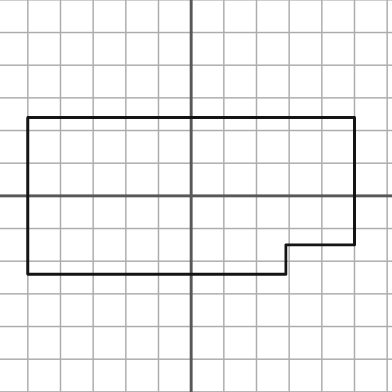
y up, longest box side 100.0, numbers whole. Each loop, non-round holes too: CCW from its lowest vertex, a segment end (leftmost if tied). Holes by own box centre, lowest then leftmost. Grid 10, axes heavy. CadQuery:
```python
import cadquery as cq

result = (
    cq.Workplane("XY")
    .moveTo(-50.0, -24.0)
    .lineTo(29.0, -24.0)
    .lineTo(29.0, -15.0)
    .lineTo(50.0, -15.0)
    .lineTo(50.0, 24.0)
    .lineTo(-50.0, 24.0)
    .close()
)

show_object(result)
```